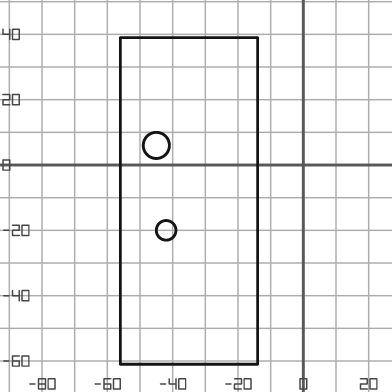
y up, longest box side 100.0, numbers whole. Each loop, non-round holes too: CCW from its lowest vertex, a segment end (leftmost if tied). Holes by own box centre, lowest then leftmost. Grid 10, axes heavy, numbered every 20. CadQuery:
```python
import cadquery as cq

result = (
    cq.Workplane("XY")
    .moveTo(-56.0, -61.0)
    .lineTo(-14.0, -61.0)
    .lineTo(-14.0, 39.0)
    .lineTo(-56.0, 39.0)
    .close()
    .moveTo(-42.0, -20.0)
    .circle(3.0)
    .moveTo(-45.0, 6.0)
    .circle(4.0)
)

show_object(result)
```